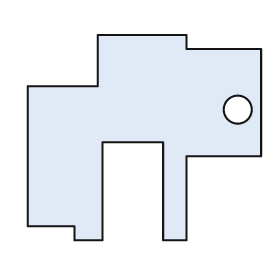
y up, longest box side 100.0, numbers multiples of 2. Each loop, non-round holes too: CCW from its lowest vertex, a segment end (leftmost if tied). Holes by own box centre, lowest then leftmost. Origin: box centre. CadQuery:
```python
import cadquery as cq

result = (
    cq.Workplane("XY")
    .moveTo(-30.0, -44.0)
    .lineTo(-18.0, -44.0)
    .lineTo(-18.0, -2.0)
    .lineTo(8.0, -2.0)
    .lineTo(8.0, -44.0)
    .lineTo(18.0, -44.0)
    .lineTo(18.0, -8.0)
    .lineTo(50.0, -8.0)
    .lineTo(50.0, 38.0)
    .lineTo(18.0, 38.0)
    .lineTo(18.0, 44.0)
    .lineTo(-20.0, 44.0)
    .lineTo(-20.0, 22.0)
    .lineTo(-50.0, 22.0)
    .lineTo(-50.0, -38.0)
    .lineTo(-30.0, -38.0)
    .close()
    .moveTo(40.0, 12.0)
    .circle(6.0)
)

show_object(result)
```